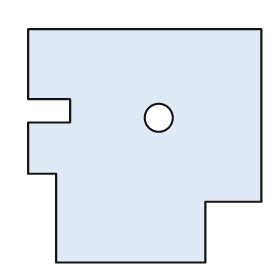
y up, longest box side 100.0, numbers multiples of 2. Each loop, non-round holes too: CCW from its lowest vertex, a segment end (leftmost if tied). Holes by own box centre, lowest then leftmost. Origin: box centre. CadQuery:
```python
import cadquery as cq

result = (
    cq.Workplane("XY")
    .moveTo(-38.0, -50.0)
    .lineTo(26.0, -50.0)
    .lineTo(26.0, -24.0)
    .lineTo(50.0, -24.0)
    .lineTo(50.0, 50.0)
    .lineTo(-50.0, 50.0)
    .lineTo(-50.0, 20.0)
    .lineTo(-32.0, 20.0)
    .lineTo(-32.0, 10.0)
    .lineTo(-50.0, 10.0)
    .lineTo(-50.0, -12.0)
    .lineTo(-38.0, -12.0)
    .close()
    .moveTo(6.0, 12.0)
    .circle(6.0)
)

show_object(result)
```